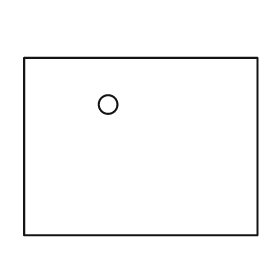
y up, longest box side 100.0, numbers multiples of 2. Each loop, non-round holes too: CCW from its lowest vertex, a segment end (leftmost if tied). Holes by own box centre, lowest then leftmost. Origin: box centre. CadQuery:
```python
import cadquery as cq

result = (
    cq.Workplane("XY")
    .moveTo(-50.0, -38.0)
    .lineTo(50.0, -38.0)
    .lineTo(50.0, 38.0)
    .lineTo(-50.0, 38.0)
    .close()
    .moveTo(-14.0, 18.0)
    .circle(4.0)
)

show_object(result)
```